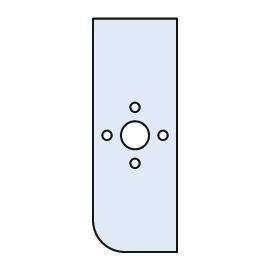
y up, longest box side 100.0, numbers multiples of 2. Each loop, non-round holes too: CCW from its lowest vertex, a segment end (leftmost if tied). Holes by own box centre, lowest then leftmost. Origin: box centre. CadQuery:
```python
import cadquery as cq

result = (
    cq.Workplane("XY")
    .moveTo(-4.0, -50.0)
    .lineTo(18.0, -50.0)
    .lineTo(18.0, 50.0)
    .lineTo(-18.0, 50.0)
    .lineTo(-18.0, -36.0)
    .threePointArc((-14.0, -46.0), (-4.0, -50.0))
    .close()
    .moveTo(0.0, -12.0)
    .circle(2.0)
    .moveTo(-12.0, 0.0)
    .circle(2.0)
    .moveTo(0.0, 0.0)
    .circle(6.0)
    .moveTo(12.0, 0.0)
    .circle(2.0)
    .moveTo(0.0, 12.0)
    .circle(2.0)
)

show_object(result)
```